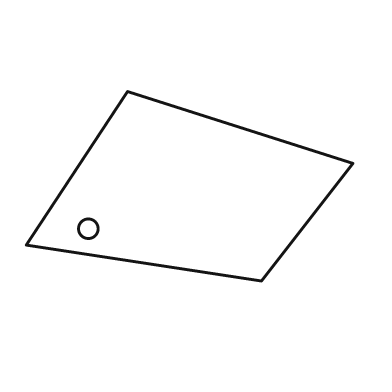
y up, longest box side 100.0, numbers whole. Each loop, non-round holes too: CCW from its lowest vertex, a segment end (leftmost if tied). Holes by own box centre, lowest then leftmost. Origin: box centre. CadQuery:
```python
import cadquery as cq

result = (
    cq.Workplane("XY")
    .moveTo(22.0, -29.0)
    .lineTo(50.0, 7.0)
    .lineTo(-19.0, 29.0)
    .lineTo(-50.0, -18.0)
    .close()
    .moveTo(-31.0, -13.0)
    .circle(3.0)
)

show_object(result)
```